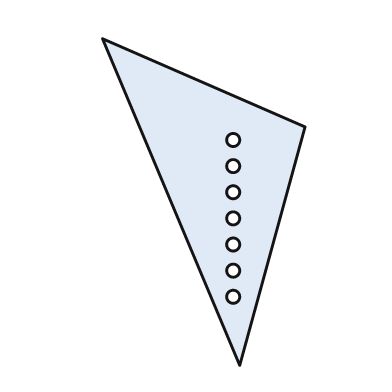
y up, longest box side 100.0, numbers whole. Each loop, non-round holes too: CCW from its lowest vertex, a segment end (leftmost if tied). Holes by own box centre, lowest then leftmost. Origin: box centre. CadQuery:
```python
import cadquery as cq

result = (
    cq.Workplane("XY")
    .moveTo(11.0, -50.0)
    .lineTo(31.0, 23.0)
    .lineTo(-31.0, 50.0)
    .close()
    .moveTo(9.0, -29.0)
    .circle(2.0)
    .moveTo(9.0, -21.0)
    .circle(2.0)
    .moveTo(9.0, -13.0)
    .circle(2.0)
    .moveTo(9.0, -5.0)
    .circle(2.0)
    .moveTo(9.0, 3.0)
    .circle(2.0)
    .moveTo(9.0, 11.0)
    .circle(2.0)
    .moveTo(9.0, 19.0)
    .circle(2.0)
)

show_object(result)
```